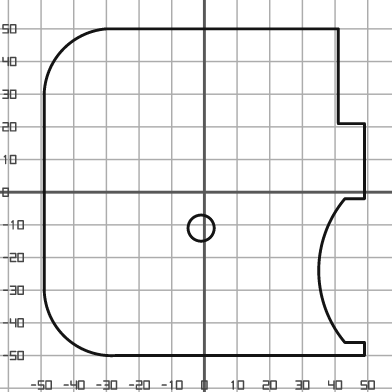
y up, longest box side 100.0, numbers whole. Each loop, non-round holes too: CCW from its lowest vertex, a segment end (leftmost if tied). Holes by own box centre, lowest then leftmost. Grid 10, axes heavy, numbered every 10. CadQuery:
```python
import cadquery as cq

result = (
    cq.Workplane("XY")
    .moveTo(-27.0, -50.0)
    .lineTo(49.0, -50.0)
    .lineTo(49.0, -46.0)
    .lineTo(43.0, -46.0)
    .threePointArc((35.0, -24.0), (43.0, -2.0))
    .lineTo(49.0, -2.0)
    .lineTo(49.0, 21.0)
    .lineTo(41.0, 21.0)
    .lineTo(41.0, 50.0)
    .lineTo(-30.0, 50.0)
    .threePointArc((-43.0, 44.0), (-49.0, 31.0))
    .lineTo(-49.0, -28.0)
    .threePointArc((-43.0, -44.0), (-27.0, -50.0))
    .close()
    .moveTo(-1.0, -11.0)
    .circle(4.0)
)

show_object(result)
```